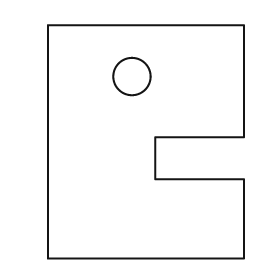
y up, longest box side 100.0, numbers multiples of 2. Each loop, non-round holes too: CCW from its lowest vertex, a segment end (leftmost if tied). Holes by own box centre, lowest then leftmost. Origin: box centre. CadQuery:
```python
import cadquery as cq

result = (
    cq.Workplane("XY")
    .moveTo(-42.0, -50.0)
    .lineTo(42.0, -50.0)
    .lineTo(42.0, -16.0)
    .lineTo(4.0, -16.0)
    .lineTo(4.0, 2.0)
    .lineTo(42.0, 2.0)
    .lineTo(42.0, 50.0)
    .lineTo(-42.0, 50.0)
    .close()
    .moveTo(-6.0, 28.0)
    .circle(8.0)
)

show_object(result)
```